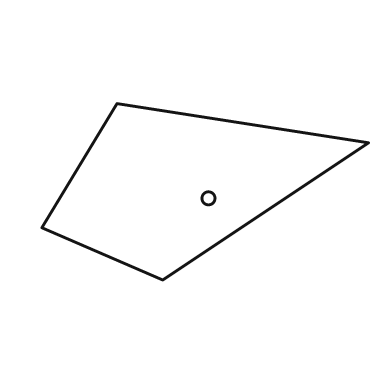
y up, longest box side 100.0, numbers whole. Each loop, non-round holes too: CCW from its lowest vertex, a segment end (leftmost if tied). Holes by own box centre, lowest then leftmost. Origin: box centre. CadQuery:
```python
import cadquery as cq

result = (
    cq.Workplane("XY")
    .moveTo(-13.0, -27.0)
    .lineTo(50.0, 15.0)
    .lineTo(-27.0, 27.0)
    .lineTo(-50.0, -11.0)
    .close()
    .moveTo(1.0, -2.0)
    .circle(2.0)
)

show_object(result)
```